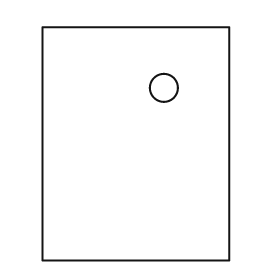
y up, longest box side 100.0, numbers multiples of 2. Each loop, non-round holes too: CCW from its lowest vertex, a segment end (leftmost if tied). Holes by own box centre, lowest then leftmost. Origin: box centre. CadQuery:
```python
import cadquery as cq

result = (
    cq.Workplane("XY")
    .moveTo(-40.0, -50.0)
    .lineTo(40.0, -50.0)
    .lineTo(40.0, 50.0)
    .lineTo(-40.0, 50.0)
    .close()
    .moveTo(12.0, 24.0)
    .circle(6.0)
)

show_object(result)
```